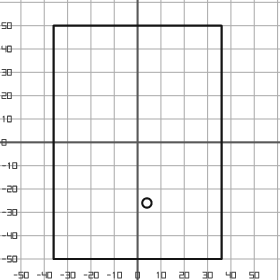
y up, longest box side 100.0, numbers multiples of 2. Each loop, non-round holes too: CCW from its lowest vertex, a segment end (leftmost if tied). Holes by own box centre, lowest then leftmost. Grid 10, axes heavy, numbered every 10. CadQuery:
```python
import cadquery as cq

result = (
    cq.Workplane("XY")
    .moveTo(-36.0, -50.0)
    .lineTo(36.0, -50.0)
    .lineTo(36.0, 50.0)
    .lineTo(-36.0, 50.0)
    .close()
    .moveTo(4.0, -26.0)
    .circle(2.0)
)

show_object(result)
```